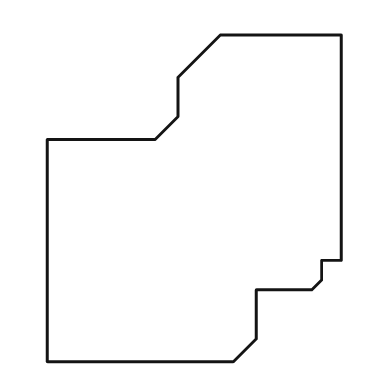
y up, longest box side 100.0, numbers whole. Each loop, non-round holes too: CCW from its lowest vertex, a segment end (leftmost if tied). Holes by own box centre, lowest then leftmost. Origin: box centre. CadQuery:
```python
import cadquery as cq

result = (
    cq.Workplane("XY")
    .moveTo(-45.0, -50.0)
    .lineTo(12.0, -50.0)
    .lineTo(19.0, -43.0)
    .lineTo(19.0, -28.0)
    .lineTo(36.0, -28.0)
    .lineTo(39.0, -25.0)
    .lineTo(39.0, -19.0)
    .lineTo(45.0, -19.0)
    .lineTo(45.0, 50.0)
    .lineTo(8.0, 50.0)
    .lineTo(-5.0, 37.0)
    .lineTo(-5.0, 25.0)
    .lineTo(-12.0, 18.0)
    .lineTo(-45.0, 18.0)
    .close()
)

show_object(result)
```